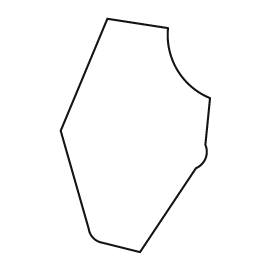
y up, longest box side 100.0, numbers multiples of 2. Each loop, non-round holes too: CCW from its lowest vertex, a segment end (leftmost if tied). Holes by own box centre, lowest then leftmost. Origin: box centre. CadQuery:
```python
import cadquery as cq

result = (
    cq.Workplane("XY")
    .moveTo(2.0, -50.0)
    .lineTo(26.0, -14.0)
    .threePointArc((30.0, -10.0), (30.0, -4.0))
    .lineTo(32.0, 16.0)
    .threePointArc((18.0, 28.0), (14.0, 46.0))
    .lineTo(-12.0, 50.0)
    .lineTo(-32.0, 2.0)
    .lineTo(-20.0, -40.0)
    .threePointArc((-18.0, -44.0), (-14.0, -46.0))
    .close()
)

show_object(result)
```